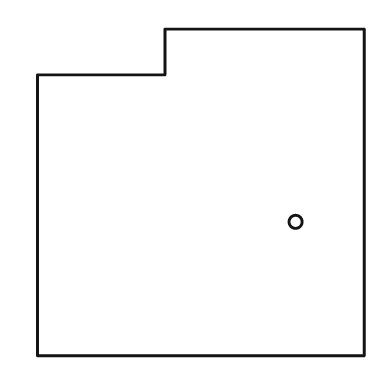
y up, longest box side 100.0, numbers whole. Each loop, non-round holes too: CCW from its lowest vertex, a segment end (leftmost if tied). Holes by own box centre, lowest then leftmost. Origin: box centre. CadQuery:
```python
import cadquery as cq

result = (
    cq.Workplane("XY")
    .moveTo(-50.0, -50.0)
    .lineTo(50.0, -50.0)
    .lineTo(50.0, 50.0)
    .lineTo(-11.0, 50.0)
    .lineTo(-11.0, 36.0)
    .lineTo(-50.0, 36.0)
    .close()
    .moveTo(29.0, -9.0)
    .circle(2.0)
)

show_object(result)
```